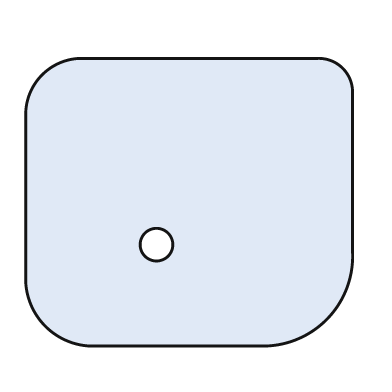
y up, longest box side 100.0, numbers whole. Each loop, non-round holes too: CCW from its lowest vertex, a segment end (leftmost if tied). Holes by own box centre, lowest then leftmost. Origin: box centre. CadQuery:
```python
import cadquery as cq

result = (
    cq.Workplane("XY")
    .moveTo(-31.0, -44.0)
    .lineTo(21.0, -44.0)
    .threePointArc((42.0, -36.0), (50.0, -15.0))
    .lineTo(50.0, 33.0)
    .threePointArc((47.0, 41.0), (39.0, 44.0))
    .lineTo(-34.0, 44.0)
    .threePointArc((-45.0, 39.0), (-50.0, 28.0))
    .lineTo(-50.0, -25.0)
    .threePointArc((-44.0, -38.0), (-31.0, -44.0))
    .close()
    .moveTo(-10.0, -13.0)
    .circle(5.0)
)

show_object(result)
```